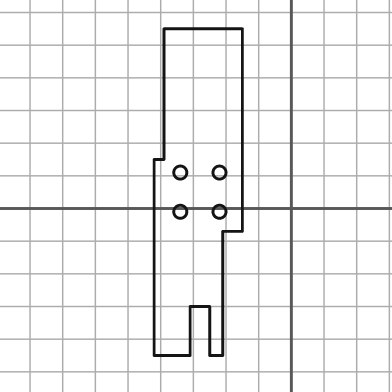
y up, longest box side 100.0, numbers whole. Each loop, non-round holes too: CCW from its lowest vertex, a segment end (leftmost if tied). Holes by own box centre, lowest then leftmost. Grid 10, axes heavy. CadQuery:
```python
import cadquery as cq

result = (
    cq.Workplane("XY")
    .moveTo(-42.0, -45.0)
    .lineTo(-31.0, -45.0)
    .lineTo(-31.0, -30.0)
    .lineTo(-25.0, -30.0)
    .lineTo(-25.0, -45.0)
    .lineTo(-21.0, -45.0)
    .lineTo(-21.0, -7.0)
    .lineTo(-15.0, -7.0)
    .lineTo(-15.0, 55.0)
    .lineTo(-39.0, 55.0)
    .lineTo(-39.0, 15.0)
    .lineTo(-42.0, 15.0)
    .close()
    .moveTo(-34.0, -1.0)
    .circle(2.0)
    .moveTo(-22.0, -1.0)
    .circle(2.0)
    .moveTo(-34.0, 11.0)
    .circle(2.0)
    .moveTo(-22.0, 11.0)
    .circle(2.0)
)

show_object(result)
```